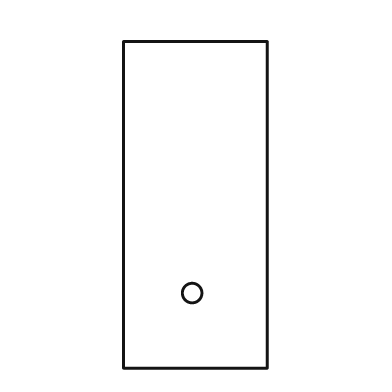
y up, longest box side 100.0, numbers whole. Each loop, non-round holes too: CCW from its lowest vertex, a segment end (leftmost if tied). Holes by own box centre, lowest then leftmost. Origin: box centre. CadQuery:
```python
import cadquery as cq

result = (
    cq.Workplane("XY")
    .moveTo(-22.0, -50.0)
    .lineTo(22.0, -50.0)
    .lineTo(22.0, 50.0)
    .lineTo(-22.0, 50.0)
    .close()
    .moveTo(-1.0, -27.0)
    .circle(3.0)
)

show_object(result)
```